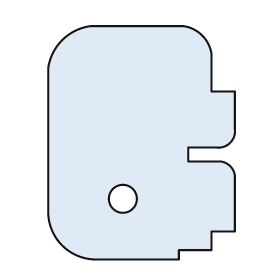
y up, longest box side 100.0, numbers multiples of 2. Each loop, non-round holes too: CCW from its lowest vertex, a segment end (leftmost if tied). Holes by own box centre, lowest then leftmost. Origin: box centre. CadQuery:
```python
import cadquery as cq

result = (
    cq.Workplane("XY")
    .moveTo(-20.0, -50.0)
    .lineTo(16.0, -50.0)
    .lineTo(16.0, -46.0)
    .lineTo(30.0, -46.0)
    .lineTo(30.0, -38.0)
    .lineTo(40.0, -38.0)
    .lineTo(40.0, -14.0)
    .threePointArc((38.0, -10.0), (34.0, -8.0))
    .lineTo(20.0, -8.0)
    .lineTo(20.0, -2.0)
    .lineTo(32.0, -2.0)
    .threePointArc((38.0, 0.0), (40.0, 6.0))
    .lineTo(40.0, 22.0)
    .lineTo(30.0, 22.0)
    .lineTo(30.0, 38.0)
    .threePointArc((26.0, 46.0), (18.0, 50.0))
    .lineTo(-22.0, 50.0)
    .threePointArc((-34.0, 44.0), (-40.0, 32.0))
    .lineTo(-40.0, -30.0)
    .threePointArc((-34.0, -44.0), (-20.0, -50.0))
    .close()
    .moveTo(-8.0, -24.0)
    .circle(6.0)
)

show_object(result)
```